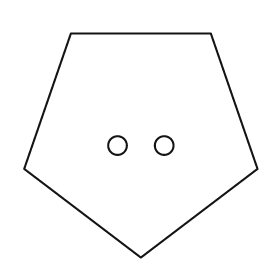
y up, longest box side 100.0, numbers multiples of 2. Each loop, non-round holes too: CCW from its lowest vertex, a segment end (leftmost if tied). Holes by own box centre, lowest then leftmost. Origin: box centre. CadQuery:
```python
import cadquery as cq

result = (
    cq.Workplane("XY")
    .moveTo(0.0, -48.0)
    .lineTo(50.0, -10.0)
    .lineTo(30.0, 48.0)
    .lineTo(-30.0, 48.0)
    .lineTo(-50.0, -10.0)
    .close()
    .moveTo(-10.0, 0.0)
    .circle(4.0)
    .moveTo(10.0, 0.0)
    .circle(4.0)
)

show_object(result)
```